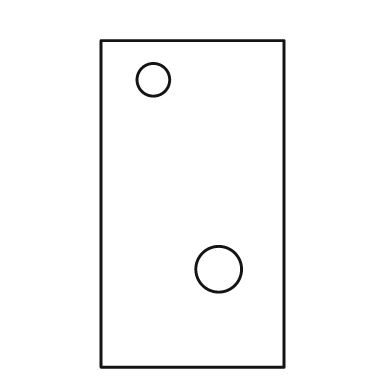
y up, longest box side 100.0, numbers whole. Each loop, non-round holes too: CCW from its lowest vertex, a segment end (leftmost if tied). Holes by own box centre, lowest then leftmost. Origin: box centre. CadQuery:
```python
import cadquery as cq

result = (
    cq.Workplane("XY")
    .moveTo(-28.0, -50.0)
    .lineTo(28.0, -50.0)
    .lineTo(28.0, 50.0)
    .lineTo(-28.0, 50.0)
    .close()
    .moveTo(8.0, -20.0)
    .circle(7.0)
    .moveTo(-12.0, 38.0)
    .circle(5.0)
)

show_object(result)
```